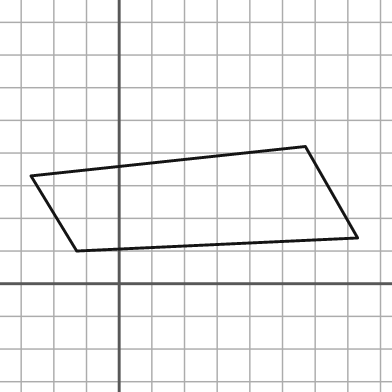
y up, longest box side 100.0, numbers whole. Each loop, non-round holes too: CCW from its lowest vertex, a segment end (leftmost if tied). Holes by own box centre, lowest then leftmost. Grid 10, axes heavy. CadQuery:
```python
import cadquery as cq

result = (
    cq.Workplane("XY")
    .moveTo(-13.0, 10.0)
    .lineTo(73.0, 14.0)
    .lineTo(57.0, 42.0)
    .lineTo(-27.0, 33.0)
    .close()
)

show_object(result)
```